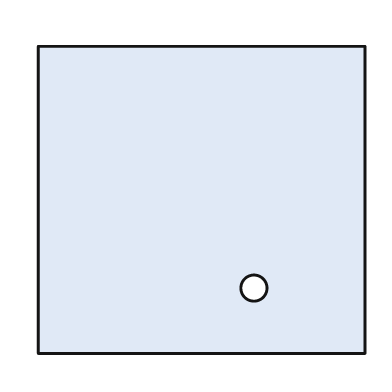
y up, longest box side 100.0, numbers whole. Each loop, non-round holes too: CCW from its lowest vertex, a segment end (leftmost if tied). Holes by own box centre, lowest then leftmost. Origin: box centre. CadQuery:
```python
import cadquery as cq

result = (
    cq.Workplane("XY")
    .moveTo(-50.0, -47.0)
    .lineTo(50.0, -47.0)
    .lineTo(50.0, 47.0)
    .lineTo(-50.0, 47.0)
    .close()
    .moveTo(16.0, -27.0)
    .circle(4.0)
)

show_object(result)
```